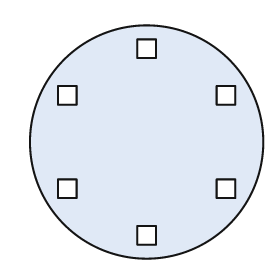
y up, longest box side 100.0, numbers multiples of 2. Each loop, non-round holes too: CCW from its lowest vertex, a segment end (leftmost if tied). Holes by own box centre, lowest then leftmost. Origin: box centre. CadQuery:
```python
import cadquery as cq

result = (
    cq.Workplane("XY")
    .moveTo(0.0, 0.0)
    .circle(50.0)
    .moveTo(-4.0, -44.0)
    .lineTo(4.0, -44.0)
    .lineTo(4.0, -36.0)
    .lineTo(-4.0, -36.0)
    .close()
    .moveTo(-38.0, -24.0)
    .lineTo(-30.0, -24.0)
    .lineTo(-30.0, -16.0)
    .lineTo(-38.0, -16.0)
    .close()
    .moveTo(30.0, -24.0)
    .lineTo(38.0, -24.0)
    .lineTo(38.0, -16.0)
    .lineTo(30.0, -16.0)
    .close()
    .moveTo(-38.0, 16.0)
    .lineTo(-30.0, 16.0)
    .lineTo(-30.0, 24.0)
    .lineTo(-38.0, 24.0)
    .close()
    .moveTo(30.0, 16.0)
    .lineTo(38.0, 16.0)
    .lineTo(38.0, 24.0)
    .lineTo(30.0, 24.0)
    .close()
    .moveTo(-4.0, 36.0)
    .lineTo(4.0, 36.0)
    .lineTo(4.0, 44.0)
    .lineTo(-4.0, 44.0)
    .close()
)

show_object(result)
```